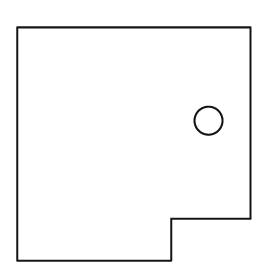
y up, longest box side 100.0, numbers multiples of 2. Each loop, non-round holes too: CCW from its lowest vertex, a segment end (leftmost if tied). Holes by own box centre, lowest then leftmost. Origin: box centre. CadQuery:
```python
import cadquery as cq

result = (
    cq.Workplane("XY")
    .moveTo(-50.0, -50.0)
    .lineTo(16.0, -50.0)
    .lineTo(16.0, -32.0)
    .lineTo(50.0, -32.0)
    .lineTo(50.0, 50.0)
    .lineTo(-50.0, 50.0)
    .close()
    .moveTo(32.0, 10.0)
    .circle(6.0)
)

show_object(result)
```